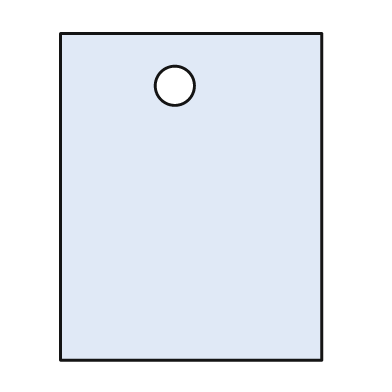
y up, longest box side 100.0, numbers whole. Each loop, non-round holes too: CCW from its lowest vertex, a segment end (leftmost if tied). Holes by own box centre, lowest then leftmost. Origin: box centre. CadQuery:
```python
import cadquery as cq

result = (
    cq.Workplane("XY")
    .moveTo(-40.0, -50.0)
    .lineTo(40.0, -50.0)
    .lineTo(40.0, 50.0)
    .lineTo(-40.0, 50.0)
    .close()
    .moveTo(-5.0, 34.0)
    .circle(6.0)
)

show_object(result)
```